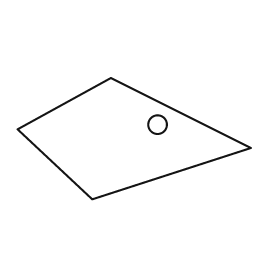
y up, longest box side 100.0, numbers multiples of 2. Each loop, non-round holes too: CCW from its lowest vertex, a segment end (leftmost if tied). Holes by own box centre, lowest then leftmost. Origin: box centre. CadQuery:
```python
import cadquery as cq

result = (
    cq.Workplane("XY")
    .moveTo(-18.0, -26.0)
    .lineTo(50.0, -4.0)
    .lineTo(-10.0, 26.0)
    .lineTo(-50.0, 4.0)
    .close()
    .moveTo(10.0, 6.0)
    .circle(4.0)
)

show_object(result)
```